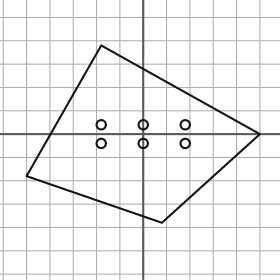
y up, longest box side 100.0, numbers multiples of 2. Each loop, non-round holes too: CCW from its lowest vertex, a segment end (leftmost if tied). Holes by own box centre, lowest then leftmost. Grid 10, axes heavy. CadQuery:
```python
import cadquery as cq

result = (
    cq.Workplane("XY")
    .moveTo(8.0, -38.0)
    .lineTo(50.0, 0.0)
    .lineTo(-18.0, 38.0)
    .lineTo(-50.0, -18.0)
    .close()
    .moveTo(-18.0, -4.0)
    .circle(2.0)
    .moveTo(0.0, -4.0)
    .circle(2.0)
    .moveTo(18.0, -4.0)
    .circle(2.0)
    .moveTo(-18.0, 4.0)
    .circle(2.0)
    .moveTo(0.0, 4.0)
    .circle(2.0)
    .moveTo(18.0, 4.0)
    .circle(2.0)
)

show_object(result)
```